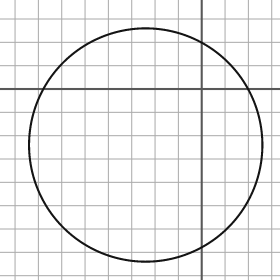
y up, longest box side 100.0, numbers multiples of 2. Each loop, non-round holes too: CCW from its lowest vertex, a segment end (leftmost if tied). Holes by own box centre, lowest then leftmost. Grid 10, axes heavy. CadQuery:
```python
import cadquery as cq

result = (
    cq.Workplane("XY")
    .moveTo(-24.0, -24.0)
    .circle(50.0)
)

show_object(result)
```